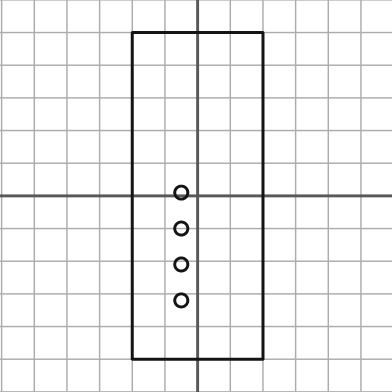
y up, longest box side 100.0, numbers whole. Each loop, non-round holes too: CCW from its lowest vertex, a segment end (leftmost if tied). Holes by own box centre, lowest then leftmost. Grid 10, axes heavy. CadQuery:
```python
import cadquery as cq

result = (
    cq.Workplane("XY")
    .moveTo(-20.0, -50.0)
    .lineTo(20.0, -50.0)
    .lineTo(20.0, 50.0)
    .lineTo(-20.0, 50.0)
    .close()
    .moveTo(-5.0, -32.0)
    .circle(2.0)
    .moveTo(-5.0, -21.0)
    .circle(2.0)
    .moveTo(-5.0, -10.0)
    .circle(2.0)
    .moveTo(-5.0, 1.0)
    .circle(2.0)
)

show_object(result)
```